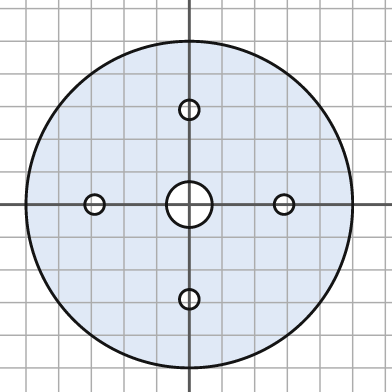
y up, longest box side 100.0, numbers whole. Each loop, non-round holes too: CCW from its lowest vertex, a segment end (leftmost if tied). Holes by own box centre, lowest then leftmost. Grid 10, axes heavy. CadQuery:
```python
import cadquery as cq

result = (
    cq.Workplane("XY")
    .moveTo(0.0, 0.0)
    .circle(50.0)
    .moveTo(0.0, -29.0)
    .circle(3.0)
    .moveTo(-29.0, 0.0)
    .circle(3.0)
    .moveTo(0.0, 0.0)
    .circle(7.0)
    .moveTo(29.0, 0.0)
    .circle(3.0)
    .moveTo(0.0, 29.0)
    .circle(3.0)
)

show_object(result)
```